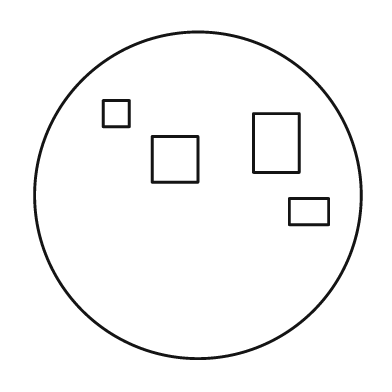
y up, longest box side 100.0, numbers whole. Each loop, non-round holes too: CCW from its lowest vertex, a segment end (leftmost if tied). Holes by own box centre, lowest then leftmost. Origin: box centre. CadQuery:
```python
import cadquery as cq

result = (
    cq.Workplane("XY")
    .moveTo(0.0, 0.0)
    .circle(50.0)
    .moveTo(28.0, -9.0)
    .lineTo(40.0, -9.0)
    .lineTo(40.0, -1.0)
    .lineTo(28.0, -1.0)
    .close()
    .moveTo(-14.0, 4.0)
    .lineTo(0.0, 4.0)
    .lineTo(0.0, 18.0)
    .lineTo(-14.0, 18.0)
    .close()
    .moveTo(17.0, 7.0)
    .lineTo(31.0, 7.0)
    .lineTo(31.0, 25.0)
    .lineTo(17.0, 25.0)
    .close()
    .moveTo(-29.0, 21.0)
    .lineTo(-21.0, 21.0)
    .lineTo(-21.0, 29.0)
    .lineTo(-29.0, 29.0)
    .close()
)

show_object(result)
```